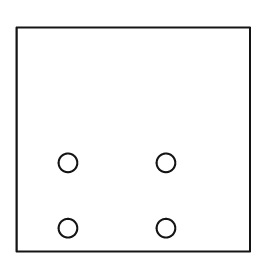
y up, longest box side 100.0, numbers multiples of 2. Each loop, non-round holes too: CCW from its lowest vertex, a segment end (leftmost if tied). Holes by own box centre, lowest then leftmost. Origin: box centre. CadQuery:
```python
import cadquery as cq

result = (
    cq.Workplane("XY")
    .moveTo(-50.0, -48.0)
    .lineTo(50.0, -48.0)
    .lineTo(50.0, 48.0)
    .lineTo(-50.0, 48.0)
    .close()
    .moveTo(-28.0, -38.0)
    .circle(4.0)
    .moveTo(14.0, -38.0)
    .circle(4.0)
    .moveTo(-28.0, -10.0)
    .circle(4.0)
    .moveTo(14.0, -10.0)
    .circle(4.0)
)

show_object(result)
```